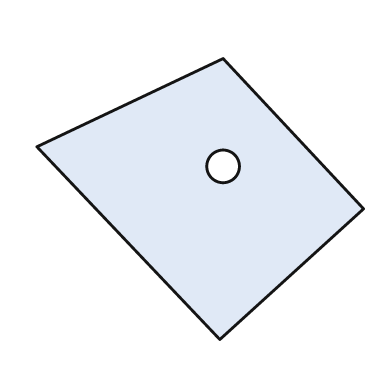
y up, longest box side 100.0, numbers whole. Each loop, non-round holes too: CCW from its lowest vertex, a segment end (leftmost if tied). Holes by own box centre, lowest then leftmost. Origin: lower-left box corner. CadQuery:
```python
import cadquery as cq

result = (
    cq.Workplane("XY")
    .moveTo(56.0, 0.0)
    .lineTo(100.0, 40.0)
    .lineTo(57.0, 86.0)
    .lineTo(0.0, 59.0)
    .close()
    .moveTo(57.0, 53.0)
    .circle(5.0)
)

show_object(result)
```